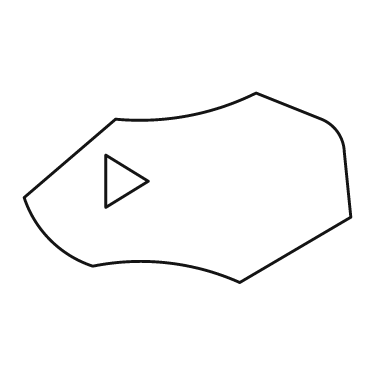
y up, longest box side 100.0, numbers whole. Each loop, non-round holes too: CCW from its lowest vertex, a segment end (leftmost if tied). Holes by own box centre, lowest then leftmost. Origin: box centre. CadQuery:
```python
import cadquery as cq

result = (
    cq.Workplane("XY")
    .moveTo(16.0, -29.0)
    .lineTo(50.0, -9.0)
    .lineTo(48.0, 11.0)
    .threePointArc((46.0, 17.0), (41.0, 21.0))
    .lineTo(21.0, 29.0)
    .threePointArc((0.0, 22.0), (-22.0, 21.0))
    .lineTo(-50.0, -3.0)
    .threePointArc((-42.0, -16.0), (-29.0, -24.0))
    .threePointArc((-6.0, -23.0), (16.0, -29.0))
    .close()
    .moveTo(-25.0, -6.0)
    .lineTo(-12.0, 2.0)
    .lineTo(-25.0, 10.0)
    .close()
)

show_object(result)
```